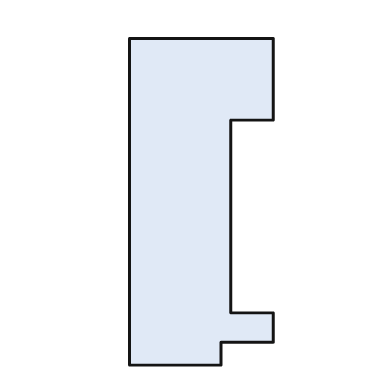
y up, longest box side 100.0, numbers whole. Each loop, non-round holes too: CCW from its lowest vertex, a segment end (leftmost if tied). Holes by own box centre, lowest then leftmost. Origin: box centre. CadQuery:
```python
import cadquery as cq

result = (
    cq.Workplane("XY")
    .moveTo(-22.0, -50.0)
    .lineTo(6.0, -50.0)
    .lineTo(6.0, -43.0)
    .lineTo(22.0, -43.0)
    .lineTo(22.0, -34.0)
    .lineTo(9.0, -34.0)
    .lineTo(9.0, 25.0)
    .lineTo(22.0, 25.0)
    .lineTo(22.0, 50.0)
    .lineTo(-22.0, 50.0)
    .close()
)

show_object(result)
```